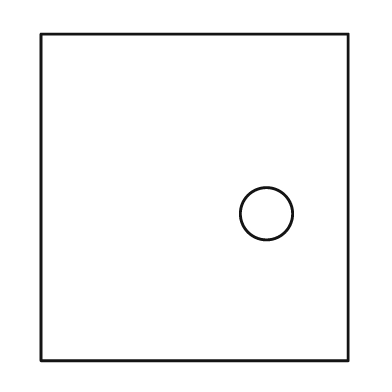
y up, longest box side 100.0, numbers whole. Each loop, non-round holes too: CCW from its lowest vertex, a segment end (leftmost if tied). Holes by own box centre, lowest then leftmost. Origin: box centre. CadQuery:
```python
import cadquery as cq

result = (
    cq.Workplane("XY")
    .moveTo(-47.0, -50.0)
    .lineTo(47.0, -50.0)
    .lineTo(47.0, 50.0)
    .lineTo(-47.0, 50.0)
    .close()
    .moveTo(22.0, -5.0)
    .circle(8.0)
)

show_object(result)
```